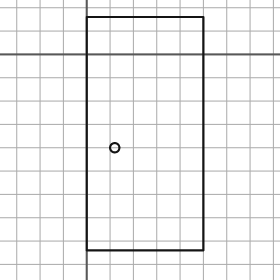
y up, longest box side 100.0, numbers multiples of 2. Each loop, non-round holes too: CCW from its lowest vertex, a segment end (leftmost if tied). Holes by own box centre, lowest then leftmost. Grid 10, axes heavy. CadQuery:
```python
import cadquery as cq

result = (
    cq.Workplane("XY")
    .moveTo(0.0, -84.0)
    .lineTo(50.0, -84.0)
    .lineTo(50.0, 16.0)
    .lineTo(0.0, 16.0)
    .close()
    .moveTo(12.0, -40.0)
    .circle(2.0)
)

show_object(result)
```